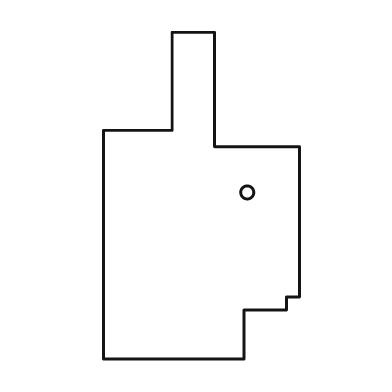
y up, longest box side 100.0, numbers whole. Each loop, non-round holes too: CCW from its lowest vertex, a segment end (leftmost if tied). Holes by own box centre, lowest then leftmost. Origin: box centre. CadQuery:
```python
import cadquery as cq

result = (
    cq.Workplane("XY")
    .moveTo(-30.0, -50.0)
    .lineTo(13.0, -50.0)
    .lineTo(13.0, -35.0)
    .lineTo(26.0, -35.0)
    .lineTo(26.0, -31.0)
    .lineTo(30.0, -31.0)
    .lineTo(30.0, 15.0)
    .lineTo(4.0, 15.0)
    .lineTo(4.0, 50.0)
    .lineTo(-9.0, 50.0)
    .lineTo(-9.0, 20.0)
    .lineTo(-30.0, 20.0)
    .close()
    .moveTo(14.0, 1.0)
    .circle(2.0)
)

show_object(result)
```